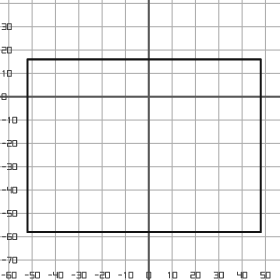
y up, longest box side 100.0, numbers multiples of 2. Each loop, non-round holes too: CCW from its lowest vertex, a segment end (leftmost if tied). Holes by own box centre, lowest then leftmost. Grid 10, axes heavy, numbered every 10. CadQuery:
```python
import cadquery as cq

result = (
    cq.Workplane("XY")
    .moveTo(-52.0, -58.0)
    .lineTo(48.0, -58.0)
    .lineTo(48.0, 16.0)
    .lineTo(-52.0, 16.0)
    .close()
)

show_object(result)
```